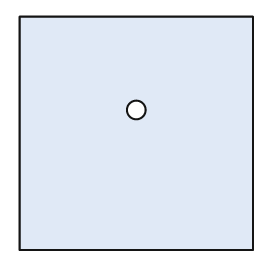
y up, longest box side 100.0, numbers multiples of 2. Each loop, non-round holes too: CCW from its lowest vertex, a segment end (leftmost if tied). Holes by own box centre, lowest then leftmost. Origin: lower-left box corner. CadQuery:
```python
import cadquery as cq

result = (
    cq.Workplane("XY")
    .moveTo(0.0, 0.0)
    .lineTo(100.0, 0.0)
    .lineTo(100.0, 100.0)
    .lineTo(0.0, 100.0)
    .close()
    .moveTo(50.0, 60.0)
    .circle(4.0)
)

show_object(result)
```